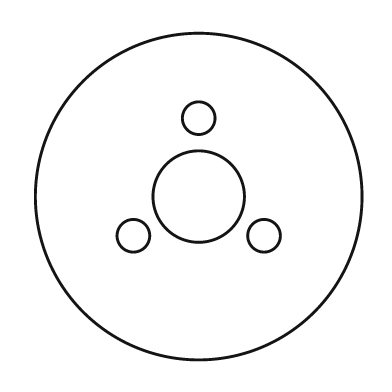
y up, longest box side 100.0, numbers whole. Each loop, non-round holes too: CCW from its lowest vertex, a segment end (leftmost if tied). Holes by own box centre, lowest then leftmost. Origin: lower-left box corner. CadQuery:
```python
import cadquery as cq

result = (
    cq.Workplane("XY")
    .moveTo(50.0, 50.0)
    .circle(50.0)
    .moveTo(30.0, 38.0)
    .circle(5.0)
    .moveTo(70.0, 38.0)
    .circle(5.0)
    .moveTo(50.0, 50.0)
    .circle(14.0)
    .moveTo(50.0, 74.0)
    .circle(5.0)
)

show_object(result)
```